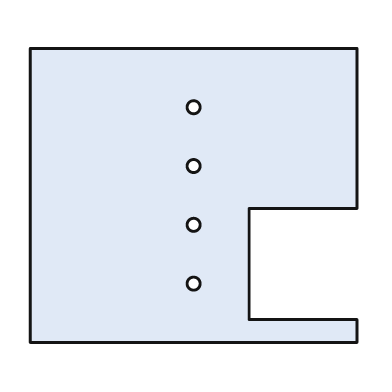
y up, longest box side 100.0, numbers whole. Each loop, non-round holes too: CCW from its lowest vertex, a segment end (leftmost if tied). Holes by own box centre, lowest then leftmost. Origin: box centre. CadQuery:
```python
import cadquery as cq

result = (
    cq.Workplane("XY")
    .moveTo(-50.0, -45.0)
    .lineTo(50.0, -45.0)
    .lineTo(50.0, -38.0)
    .lineTo(17.0, -38.0)
    .lineTo(17.0, -4.0)
    .lineTo(50.0, -4.0)
    .lineTo(50.0, 45.0)
    .lineTo(-50.0, 45.0)
    .close()
    .moveTo(0.0, -27.0)
    .circle(2.0)
    .moveTo(0.0, -9.0)
    .circle(2.0)
    .moveTo(0.0, 9.0)
    .circle(2.0)
    .moveTo(0.0, 27.0)
    .circle(2.0)
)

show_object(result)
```